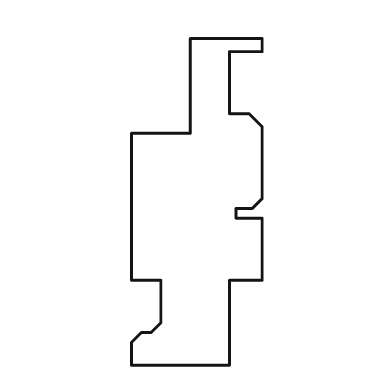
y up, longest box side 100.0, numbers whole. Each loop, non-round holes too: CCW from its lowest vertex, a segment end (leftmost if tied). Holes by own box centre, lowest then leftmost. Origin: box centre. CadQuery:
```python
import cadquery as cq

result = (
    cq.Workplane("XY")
    .moveTo(-20.0, -50.0)
    .lineTo(10.0, -50.0)
    .lineTo(10.0, -24.0)
    .lineTo(20.0, -24.0)
    .lineTo(20.0, -5.0)
    .lineTo(12.0, -5.0)
    .lineTo(12.0, -2.0)
    .lineTo(17.0, -2.0)
    .lineTo(20.0, 1.0)
    .lineTo(20.0, 23.0)
    .lineTo(16.0, 27.0)
    .lineTo(10.0, 27.0)
    .lineTo(10.0, 46.0)
    .lineTo(20.0, 46.0)
    .lineTo(20.0, 50.0)
    .lineTo(-2.0, 50.0)
    .lineTo(-2.0, 21.0)
    .lineTo(-20.0, 21.0)
    .lineTo(-20.0, -24.0)
    .lineTo(-11.0, -24.0)
    .lineTo(-11.0, -37.0)
    .lineTo(-14.0, -40.0)
    .lineTo(-17.0, -40.0)
    .lineTo(-20.0, -43.0)
    .close()
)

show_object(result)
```